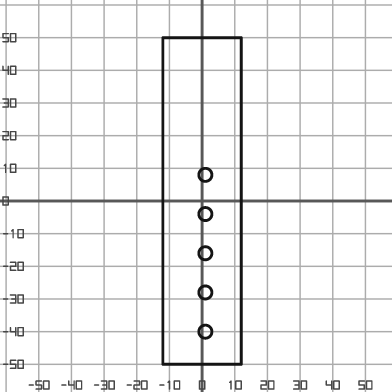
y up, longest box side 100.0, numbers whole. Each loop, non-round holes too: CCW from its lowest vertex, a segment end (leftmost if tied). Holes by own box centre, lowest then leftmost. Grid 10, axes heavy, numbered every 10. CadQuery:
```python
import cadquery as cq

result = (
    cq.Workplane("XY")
    .moveTo(-12.0, -50.0)
    .lineTo(12.0, -50.0)
    .lineTo(12.0, 50.0)
    .lineTo(-12.0, 50.0)
    .close()
    .moveTo(1.0, -40.0)
    .circle(2.0)
    .moveTo(1.0, -28.0)
    .circle(2.0)
    .moveTo(1.0, -16.0)
    .circle(2.0)
    .moveTo(1.0, -4.0)
    .circle(2.0)
    .moveTo(1.0, 8.0)
    .circle(2.0)
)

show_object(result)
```